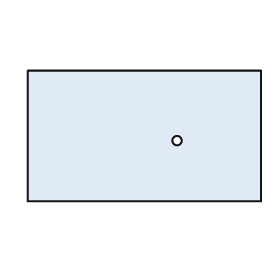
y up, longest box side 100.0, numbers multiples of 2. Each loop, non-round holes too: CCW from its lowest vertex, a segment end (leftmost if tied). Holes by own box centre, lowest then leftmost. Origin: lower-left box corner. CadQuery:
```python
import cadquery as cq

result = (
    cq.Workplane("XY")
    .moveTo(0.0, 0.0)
    .lineTo(100.0, 0.0)
    .lineTo(100.0, 56.0)
    .lineTo(0.0, 56.0)
    .close()
    .moveTo(64.0, 26.0)
    .circle(2.0)
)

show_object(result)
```